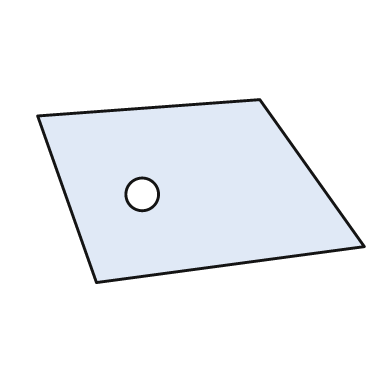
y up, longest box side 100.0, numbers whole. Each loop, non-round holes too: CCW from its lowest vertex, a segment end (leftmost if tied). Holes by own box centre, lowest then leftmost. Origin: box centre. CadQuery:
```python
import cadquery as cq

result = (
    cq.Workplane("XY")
    .moveTo(-32.0, -28.0)
    .lineTo(50.0, -17.0)
    .lineTo(18.0, 28.0)
    .lineTo(-50.0, 23.0)
    .close()
    .moveTo(-18.0, -1.0)
    .circle(5.0)
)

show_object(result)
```